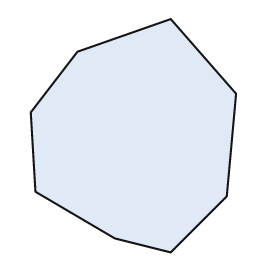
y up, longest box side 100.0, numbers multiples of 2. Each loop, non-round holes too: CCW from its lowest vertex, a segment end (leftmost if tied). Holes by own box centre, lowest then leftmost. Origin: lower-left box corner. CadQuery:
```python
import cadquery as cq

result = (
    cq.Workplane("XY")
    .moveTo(60.0, 0.0)
    .lineTo(84.0, 24.0)
    .lineTo(88.0, 68.0)
    .lineTo(60.0, 100.0)
    .lineTo(20.0, 86.0)
    .lineTo(0.0, 60.0)
    .lineTo(2.0, 26.0)
    .lineTo(36.0, 6.0)
    .close()
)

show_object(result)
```